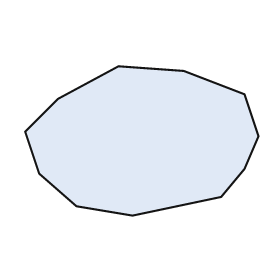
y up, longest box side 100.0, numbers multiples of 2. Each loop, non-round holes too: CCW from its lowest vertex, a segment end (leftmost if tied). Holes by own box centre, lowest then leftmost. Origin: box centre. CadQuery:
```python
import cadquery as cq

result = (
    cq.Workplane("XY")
    .moveTo(-4.0, -32.0)
    .lineTo(34.0, -24.0)
    .lineTo(44.0, -12.0)
    .lineTo(50.0, 2.0)
    .lineTo(44.0, 20.0)
    .lineTo(18.0, 30.0)
    .lineTo(-10.0, 32.0)
    .lineTo(-36.0, 18.0)
    .lineTo(-50.0, 4.0)
    .lineTo(-44.0, -14.0)
    .lineTo(-28.0, -28.0)
    .close()
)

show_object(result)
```